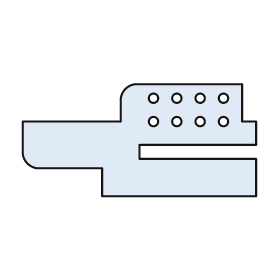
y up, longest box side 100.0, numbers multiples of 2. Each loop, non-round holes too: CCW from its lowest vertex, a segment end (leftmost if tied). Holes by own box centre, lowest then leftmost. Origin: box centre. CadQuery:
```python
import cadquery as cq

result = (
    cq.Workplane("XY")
    .moveTo(-16.0, -24.0)
    .lineTo(50.0, -24.0)
    .lineTo(50.0, -8.0)
    .lineTo(0.0, -8.0)
    .lineTo(0.0, -2.0)
    .lineTo(50.0, -2.0)
    .lineTo(50.0, 8.0)
    .lineTo(44.0, 8.0)
    .lineTo(44.0, 24.0)
    .lineTo(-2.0, 24.0)
    .threePointArc((-6.0, 22.0), (-8.0, 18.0))
    .lineTo(-8.0, 8.0)
    .lineTo(-50.0, 8.0)
    .lineTo(-50.0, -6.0)
    .threePointArc((-48.0, -10.0), (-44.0, -12.0))
    .lineTo(-16.0, -12.0)
    .close()
    .moveTo(6.0, 8.0)
    .circle(2.0)
    .moveTo(16.0, 8.0)
    .circle(2.0)
    .moveTo(26.0, 8.0)
    .circle(2.0)
    .moveTo(36.0, 8.0)
    .circle(2.0)
    .moveTo(6.0, 18.0)
    .circle(2.0)
    .moveTo(16.0, 18.0)
    .circle(2.0)
    .moveTo(26.0, 18.0)
    .circle(2.0)
    .moveTo(36.0, 18.0)
    .circle(2.0)
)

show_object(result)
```